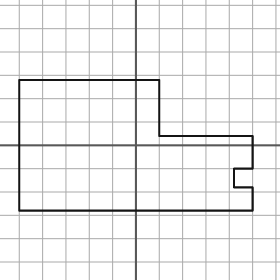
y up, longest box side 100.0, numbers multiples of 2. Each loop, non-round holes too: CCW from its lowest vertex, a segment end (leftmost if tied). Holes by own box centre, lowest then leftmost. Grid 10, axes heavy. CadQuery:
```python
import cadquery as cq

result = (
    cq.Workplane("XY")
    .moveTo(-50.0, -28.0)
    .lineTo(50.0, -28.0)
    .lineTo(50.0, -18.0)
    .lineTo(42.0, -18.0)
    .lineTo(42.0, -10.0)
    .lineTo(50.0, -10.0)
    .lineTo(50.0, 4.0)
    .lineTo(10.0, 4.0)
    .lineTo(10.0, 28.0)
    .lineTo(-50.0, 28.0)
    .close()
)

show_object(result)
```